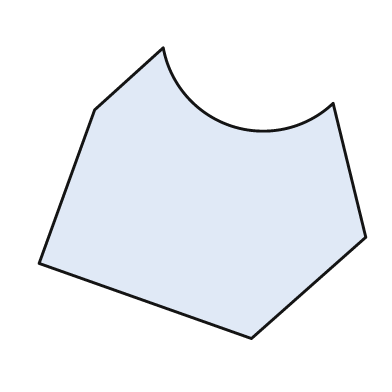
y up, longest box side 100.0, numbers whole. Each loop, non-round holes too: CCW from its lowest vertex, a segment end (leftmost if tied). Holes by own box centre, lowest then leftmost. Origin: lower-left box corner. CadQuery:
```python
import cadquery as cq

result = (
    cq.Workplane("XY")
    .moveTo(65.0, 0.0)
    .lineTo(100.0, 31.0)
    .lineTo(90.0, 72.0)
    .threePointArc((59.0, 65.0), (38.0, 89.0))
    .lineTo(17.0, 70.0)
    .lineTo(0.0, 23.0)
    .close()
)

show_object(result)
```